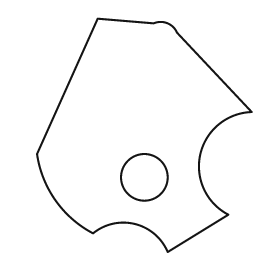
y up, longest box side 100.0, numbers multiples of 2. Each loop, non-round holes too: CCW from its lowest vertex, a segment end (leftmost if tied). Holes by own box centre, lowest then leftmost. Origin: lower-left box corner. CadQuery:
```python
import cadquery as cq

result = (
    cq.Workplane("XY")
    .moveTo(56.0, 0.0)
    .lineTo(82.0, 16.0)
    .threePointArc((70.0, 42.0), (92.0, 60.0))
    .lineTo(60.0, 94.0)
    .threePointArc((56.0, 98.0), (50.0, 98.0))
    .lineTo(26.0, 100.0)
    .lineTo(0.0, 42.0)
    .threePointArc((8.0, 22.0), (24.0, 8.0))
    .threePointArc((42.0, 12.0), (56.0, 0.0))
    .close()
    .moveTo(46.0, 32.0)
    .circle(10.0)
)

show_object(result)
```